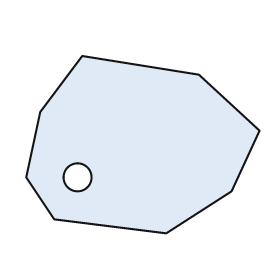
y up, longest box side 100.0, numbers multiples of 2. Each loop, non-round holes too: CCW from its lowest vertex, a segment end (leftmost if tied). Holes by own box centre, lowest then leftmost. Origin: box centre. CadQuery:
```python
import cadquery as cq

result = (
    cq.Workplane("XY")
    .moveTo(10.0, -38.0)
    .lineTo(38.0, -20.0)
    .lineTo(50.0, 6.0)
    .lineTo(24.0, 30.0)
    .lineTo(-26.0, 38.0)
    .lineTo(-44.0, 14.0)
    .lineTo(-50.0, -14.0)
    .lineTo(-38.0, -32.0)
    .close()
    .moveTo(-28.0, -14.0)
    .circle(6.0)
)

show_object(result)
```